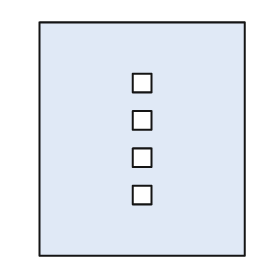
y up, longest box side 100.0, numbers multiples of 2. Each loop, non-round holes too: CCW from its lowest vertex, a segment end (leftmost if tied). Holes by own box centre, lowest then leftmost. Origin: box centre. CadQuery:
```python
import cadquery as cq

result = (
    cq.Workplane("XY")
    .moveTo(-44.0, -50.0)
    .lineTo(44.0, -50.0)
    .lineTo(44.0, 50.0)
    .lineTo(-44.0, 50.0)
    .close()
    .moveTo(-4.0, -28.0)
    .lineTo(4.0, -28.0)
    .lineTo(4.0, -20.0)
    .lineTo(-4.0, -20.0)
    .close()
    .moveTo(-4.0, -12.0)
    .lineTo(4.0, -12.0)
    .lineTo(4.0, -4.0)
    .lineTo(-4.0, -4.0)
    .close()
    .moveTo(-4.0, 4.0)
    .lineTo(4.0, 4.0)
    .lineTo(4.0, 12.0)
    .lineTo(-4.0, 12.0)
    .close()
    .moveTo(-4.0, 20.0)
    .lineTo(4.0, 20.0)
    .lineTo(4.0, 28.0)
    .lineTo(-4.0, 28.0)
    .close()
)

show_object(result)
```